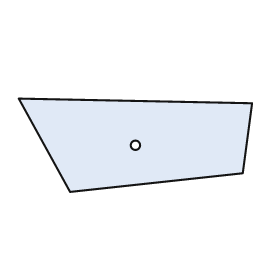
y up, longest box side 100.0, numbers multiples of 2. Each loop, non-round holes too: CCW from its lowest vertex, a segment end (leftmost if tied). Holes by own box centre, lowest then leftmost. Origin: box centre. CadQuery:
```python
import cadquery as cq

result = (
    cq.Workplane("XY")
    .moveTo(-28.0, -20.0)
    .lineTo(46.0, -12.0)
    .lineTo(50.0, 18.0)
    .lineTo(-50.0, 20.0)
    .close()
    .moveTo(0.0, 0.0)
    .circle(2.0)
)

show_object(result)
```